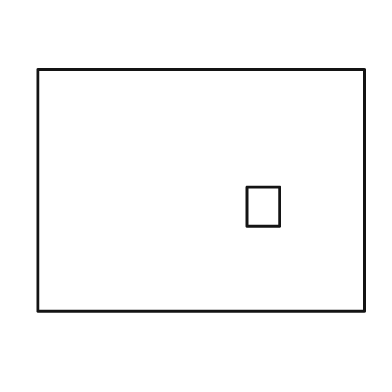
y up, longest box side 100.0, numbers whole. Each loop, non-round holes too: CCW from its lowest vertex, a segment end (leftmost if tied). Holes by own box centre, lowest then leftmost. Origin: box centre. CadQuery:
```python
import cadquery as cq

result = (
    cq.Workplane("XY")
    .moveTo(-50.0, -37.0)
    .lineTo(50.0, -37.0)
    .lineTo(50.0, 37.0)
    .lineTo(-50.0, 37.0)
    .close()
    .moveTo(14.0, -11.0)
    .lineTo(24.0, -11.0)
    .lineTo(24.0, 1.0)
    .lineTo(14.0, 1.0)
    .close()
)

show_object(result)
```